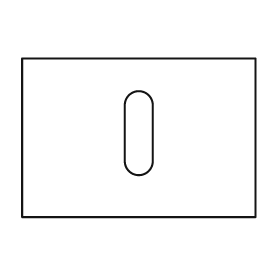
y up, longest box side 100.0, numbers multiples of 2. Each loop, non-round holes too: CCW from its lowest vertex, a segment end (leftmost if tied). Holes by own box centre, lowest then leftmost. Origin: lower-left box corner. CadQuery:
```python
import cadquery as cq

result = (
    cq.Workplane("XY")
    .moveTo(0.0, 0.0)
    .lineTo(100.0, 0.0)
    .lineTo(100.0, 68.0)
    .lineTo(0.0, 68.0)
    .close()
    .moveTo(44.0, 24.0)
    .threePointArc((50.0, 18.0), (56.0, 24.0))
    .lineTo(56.0, 48.0)
    .threePointArc((50.0, 54.0), (44.0, 48.0))
    .close()
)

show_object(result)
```